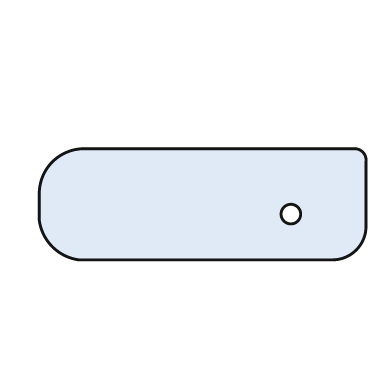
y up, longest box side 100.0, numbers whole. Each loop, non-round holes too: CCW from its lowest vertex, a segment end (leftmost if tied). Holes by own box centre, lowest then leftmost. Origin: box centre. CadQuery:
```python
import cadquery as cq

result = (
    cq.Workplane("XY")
    .moveTo(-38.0, -17.0)
    .lineTo(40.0, -17.0)
    .threePointArc((47.0, -14.0), (50.0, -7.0))
    .lineTo(50.0, 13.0)
    .threePointArc((49.0, 16.0), (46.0, 17.0))
    .lineTo(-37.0, 17.0)
    .threePointArc((-46.0, 13.0), (-50.0, 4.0))
    .lineTo(-50.0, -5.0)
    .threePointArc((-46.0, -13.0), (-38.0, -17.0))
    .close()
    .moveTo(27.0, -3.0)
    .circle(3.0)
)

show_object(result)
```